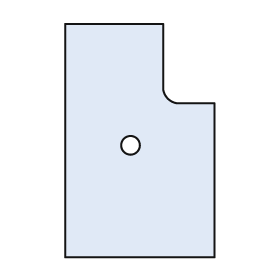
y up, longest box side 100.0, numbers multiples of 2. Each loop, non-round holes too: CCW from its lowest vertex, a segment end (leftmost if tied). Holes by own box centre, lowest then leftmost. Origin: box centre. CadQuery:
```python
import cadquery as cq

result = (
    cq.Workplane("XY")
    .moveTo(-32.0, -50.0)
    .lineTo(32.0, -50.0)
    .lineTo(32.0, 16.0)
    .lineTo(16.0, 16.0)
    .threePointArc((12.0, 18.0), (10.0, 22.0))
    .lineTo(10.0, 50.0)
    .lineTo(-32.0, 50.0)
    .close()
    .moveTo(-4.0, -2.0)
    .circle(4.0)
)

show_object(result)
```